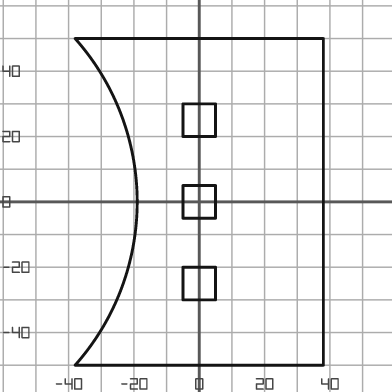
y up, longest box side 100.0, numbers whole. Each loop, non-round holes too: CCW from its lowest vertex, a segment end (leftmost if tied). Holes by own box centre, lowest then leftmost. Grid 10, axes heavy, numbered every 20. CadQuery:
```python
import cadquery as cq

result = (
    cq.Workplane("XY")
    .moveTo(-38.0, -50.0)
    .lineTo(38.0, -50.0)
    .lineTo(38.0, 50.0)
    .lineTo(-38.0, 50.0)
    .threePointArc((-19.0, 0.0), (-38.0, -50.0))
    .close()
    .moveTo(-5.0, -30.0)
    .lineTo(5.0, -30.0)
    .lineTo(5.0, -20.0)
    .lineTo(-5.0, -20.0)
    .close()
    .moveTo(-5.0, -5.0)
    .lineTo(5.0, -5.0)
    .lineTo(5.0, 5.0)
    .lineTo(-5.0, 5.0)
    .close()
    .moveTo(-5.0, 20.0)
    .lineTo(5.0, 20.0)
    .lineTo(5.0, 30.0)
    .lineTo(-5.0, 30.0)
    .close()
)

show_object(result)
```